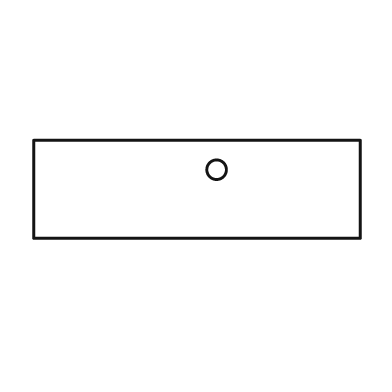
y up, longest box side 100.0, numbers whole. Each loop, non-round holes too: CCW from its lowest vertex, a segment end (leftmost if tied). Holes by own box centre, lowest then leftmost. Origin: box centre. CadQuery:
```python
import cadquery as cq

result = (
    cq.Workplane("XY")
    .moveTo(-50.0, -15.0)
    .lineTo(50.0, -15.0)
    .lineTo(50.0, 15.0)
    .lineTo(-50.0, 15.0)
    .close()
    .moveTo(6.0, 6.0)
    .circle(3.0)
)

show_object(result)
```